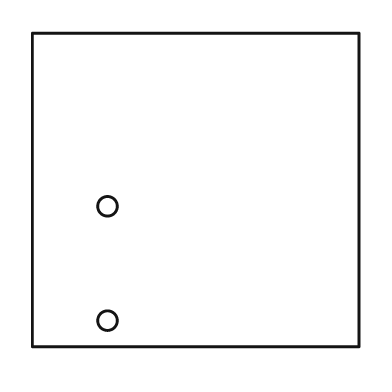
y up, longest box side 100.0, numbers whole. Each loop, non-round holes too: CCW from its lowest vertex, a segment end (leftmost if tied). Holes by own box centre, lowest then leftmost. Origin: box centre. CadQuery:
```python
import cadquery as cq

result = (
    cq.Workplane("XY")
    .moveTo(-50.0, -48.0)
    .lineTo(50.0, -48.0)
    .lineTo(50.0, 48.0)
    .lineTo(-50.0, 48.0)
    .close()
    .moveTo(-27.0, -40.0)
    .circle(3.0)
    .moveTo(-27.0, -5.0)
    .circle(3.0)
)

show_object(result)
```